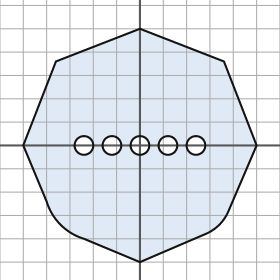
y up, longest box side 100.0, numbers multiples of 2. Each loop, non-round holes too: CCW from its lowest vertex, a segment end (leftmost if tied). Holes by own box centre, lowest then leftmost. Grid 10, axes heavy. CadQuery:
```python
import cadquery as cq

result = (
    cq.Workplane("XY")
    .moveTo(0.0, -50.0)
    .lineTo(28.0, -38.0)
    .threePointArc((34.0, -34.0), (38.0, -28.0))
    .lineTo(50.0, 0.0)
    .lineTo(36.0, 36.0)
    .lineTo(0.0, 50.0)
    .lineTo(-36.0, 36.0)
    .lineTo(-50.0, 0.0)
    .lineTo(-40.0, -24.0)
    .threePointArc((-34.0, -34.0), (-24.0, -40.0))
    .close()
    .moveTo(-24.0, 0.0)
    .circle(4.0)
    .moveTo(-12.0, 0.0)
    .circle(4.0)
    .moveTo(0.0, 0.0)
    .circle(4.0)
    .moveTo(12.0, 0.0)
    .circle(4.0)
    .moveTo(24.0, 0.0)
    .circle(4.0)
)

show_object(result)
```